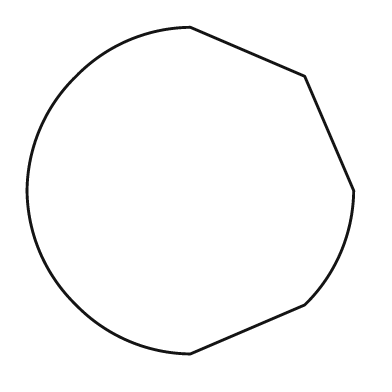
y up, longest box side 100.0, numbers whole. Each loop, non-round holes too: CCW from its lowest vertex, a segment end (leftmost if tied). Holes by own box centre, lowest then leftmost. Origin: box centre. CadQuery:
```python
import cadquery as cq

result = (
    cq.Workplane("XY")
    .moveTo(0.0, -50.0)
    .lineTo(35.0, -35.0)
    .threePointArc((46.0, -19.0), (50.0, 0.0))
    .lineTo(35.0, 35.0)
    .lineTo(0.0, 50.0)
    .threePointArc((-19.0, 46.0), (-35.0, 35.0))
    .threePointArc((-46.0, 19.0), (-50.0, 0.0))
    .threePointArc((-46.0, -19.0), (-35.0, -35.0))
    .threePointArc((-19.0, -46.0), (0.0, -50.0))
    .close()
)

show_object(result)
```